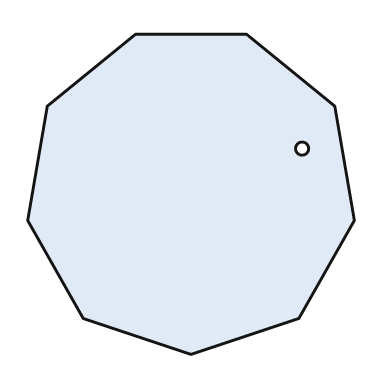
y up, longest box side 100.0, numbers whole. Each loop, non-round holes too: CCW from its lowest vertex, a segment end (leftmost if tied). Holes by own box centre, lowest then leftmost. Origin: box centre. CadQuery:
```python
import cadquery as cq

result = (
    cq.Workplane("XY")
    .moveTo(0.0, -49.0)
    .lineTo(33.0, -38.0)
    .lineTo(50.0, -8.0)
    .lineTo(44.0, 27.0)
    .lineTo(17.0, 49.0)
    .lineTo(-17.0, 49.0)
    .lineTo(-44.0, 27.0)
    .lineTo(-50.0, -8.0)
    .lineTo(-33.0, -38.0)
    .close()
    .moveTo(34.0, 14.0)
    .circle(2.0)
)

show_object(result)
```